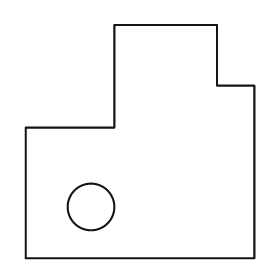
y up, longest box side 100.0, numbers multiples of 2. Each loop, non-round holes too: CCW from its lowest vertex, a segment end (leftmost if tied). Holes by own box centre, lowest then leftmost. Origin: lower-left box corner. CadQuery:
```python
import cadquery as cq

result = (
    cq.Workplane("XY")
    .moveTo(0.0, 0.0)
    .lineTo(98.0, 0.0)
    .lineTo(98.0, 74.0)
    .lineTo(82.0, 74.0)
    .lineTo(82.0, 100.0)
    .lineTo(38.0, 100.0)
    .lineTo(38.0, 56.0)
    .lineTo(0.0, 56.0)
    .close()
    .moveTo(28.0, 22.0)
    .circle(10.0)
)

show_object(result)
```